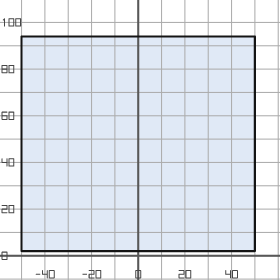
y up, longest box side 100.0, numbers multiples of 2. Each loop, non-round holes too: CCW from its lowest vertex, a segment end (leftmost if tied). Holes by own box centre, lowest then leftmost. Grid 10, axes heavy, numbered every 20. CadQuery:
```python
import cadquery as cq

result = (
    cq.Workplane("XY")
    .moveTo(-50.0, 2.0)
    .lineTo(50.0, 2.0)
    .lineTo(50.0, 94.0)
    .lineTo(-50.0, 94.0)
    .close()
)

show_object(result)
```